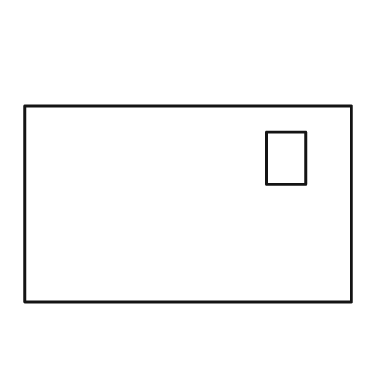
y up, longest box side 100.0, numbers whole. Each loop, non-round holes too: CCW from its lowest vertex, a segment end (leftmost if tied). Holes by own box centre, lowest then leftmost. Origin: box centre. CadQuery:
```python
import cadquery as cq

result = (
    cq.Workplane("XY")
    .moveTo(-50.0, -30.0)
    .lineTo(50.0, -30.0)
    .lineTo(50.0, 30.0)
    .lineTo(-50.0, 30.0)
    .close()
    .moveTo(24.0, 6.0)
    .lineTo(36.0, 6.0)
    .lineTo(36.0, 22.0)
    .lineTo(24.0, 22.0)
    .close()
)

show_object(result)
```